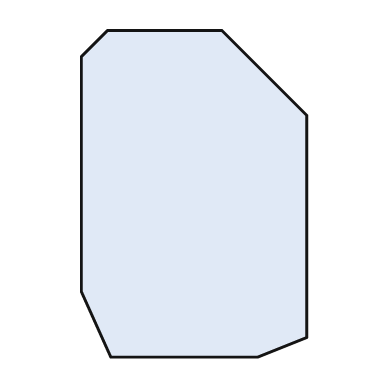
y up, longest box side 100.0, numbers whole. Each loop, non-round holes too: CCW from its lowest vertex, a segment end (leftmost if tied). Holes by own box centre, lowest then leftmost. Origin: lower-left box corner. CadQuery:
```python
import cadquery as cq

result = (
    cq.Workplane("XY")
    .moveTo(9.0, 0.0)
    .lineTo(54.0, 0.0)
    .lineTo(69.0, 6.0)
    .lineTo(69.0, 74.0)
    .lineTo(43.0, 100.0)
    .lineTo(8.0, 100.0)
    .lineTo(0.0, 92.0)
    .lineTo(0.0, 20.0)
    .close()
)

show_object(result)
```